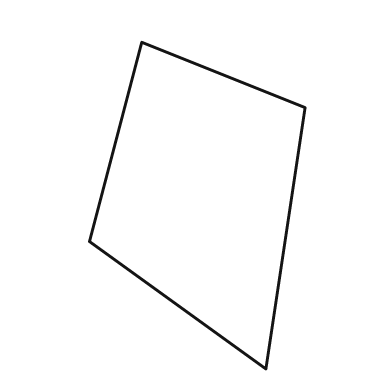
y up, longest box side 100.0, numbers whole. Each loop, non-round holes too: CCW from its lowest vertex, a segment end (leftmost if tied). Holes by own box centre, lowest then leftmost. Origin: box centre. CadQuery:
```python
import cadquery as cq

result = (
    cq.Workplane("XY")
    .moveTo(21.0, -50.0)
    .lineTo(33.0, 30.0)
    .lineTo(-17.0, 50.0)
    .lineTo(-33.0, -11.0)
    .close()
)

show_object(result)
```